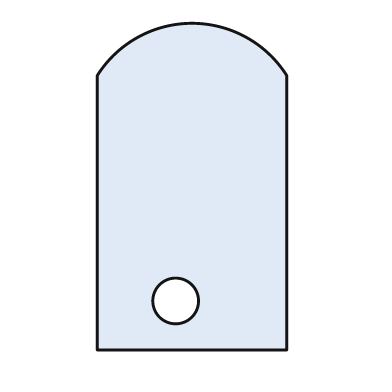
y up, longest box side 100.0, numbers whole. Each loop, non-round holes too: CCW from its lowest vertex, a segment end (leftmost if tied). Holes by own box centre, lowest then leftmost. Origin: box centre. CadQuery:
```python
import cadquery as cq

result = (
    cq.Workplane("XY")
    .moveTo(-29.0, -50.0)
    .lineTo(29.0, -50.0)
    .lineTo(29.0, 34.0)
    .threePointArc((0.0, 50.0), (-29.0, 34.0))
    .close()
    .moveTo(-5.0, -35.0)
    .circle(7.0)
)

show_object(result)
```